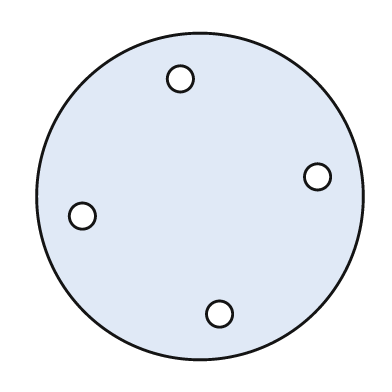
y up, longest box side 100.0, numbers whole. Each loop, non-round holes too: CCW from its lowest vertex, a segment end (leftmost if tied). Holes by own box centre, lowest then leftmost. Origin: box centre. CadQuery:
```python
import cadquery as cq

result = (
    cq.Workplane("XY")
    .moveTo(0.0, 0.0)
    .circle(50.0)
    .moveTo(6.0, -36.0)
    .circle(4.0)
    .moveTo(-36.0, -6.0)
    .circle(4.0)
    .moveTo(36.0, 6.0)
    .circle(4.0)
    .moveTo(-6.0, 36.0)
    .circle(4.0)
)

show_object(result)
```